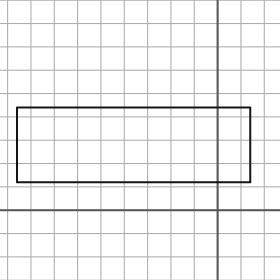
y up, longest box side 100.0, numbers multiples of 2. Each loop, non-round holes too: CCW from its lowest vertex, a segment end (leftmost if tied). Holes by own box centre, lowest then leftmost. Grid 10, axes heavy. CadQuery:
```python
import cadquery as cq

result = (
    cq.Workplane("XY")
    .moveTo(-86.0, 12.0)
    .lineTo(14.0, 12.0)
    .lineTo(14.0, 44.0)
    .lineTo(-86.0, 44.0)
    .close()
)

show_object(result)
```